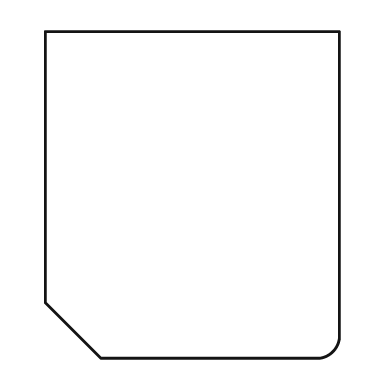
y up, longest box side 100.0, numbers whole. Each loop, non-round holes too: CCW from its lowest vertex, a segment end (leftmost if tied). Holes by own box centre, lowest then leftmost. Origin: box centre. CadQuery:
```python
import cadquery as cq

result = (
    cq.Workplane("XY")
    .moveTo(-28.0, -50.0)
    .lineTo(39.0, -50.0)
    .threePointArc((43.0, -48.0), (45.0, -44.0))
    .lineTo(45.0, 50.0)
    .lineTo(-45.0, 50.0)
    .lineTo(-45.0, -33.0)
    .close()
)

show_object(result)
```